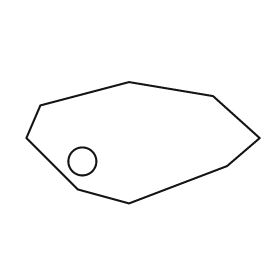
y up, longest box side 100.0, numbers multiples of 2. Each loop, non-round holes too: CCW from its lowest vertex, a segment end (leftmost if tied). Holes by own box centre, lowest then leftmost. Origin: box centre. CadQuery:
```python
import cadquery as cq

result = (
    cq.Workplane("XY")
    .moveTo(-6.0, -26.0)
    .lineTo(36.0, -10.0)
    .lineTo(50.0, 2.0)
    .lineTo(30.0, 20.0)
    .lineTo(-6.0, 26.0)
    .lineTo(-44.0, 16.0)
    .lineTo(-50.0, 2.0)
    .lineTo(-28.0, -20.0)
    .close()
    .moveTo(-26.0, -8.0)
    .circle(6.0)
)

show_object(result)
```